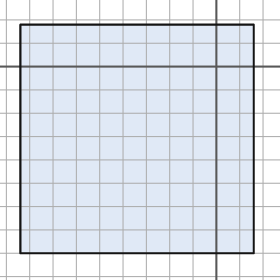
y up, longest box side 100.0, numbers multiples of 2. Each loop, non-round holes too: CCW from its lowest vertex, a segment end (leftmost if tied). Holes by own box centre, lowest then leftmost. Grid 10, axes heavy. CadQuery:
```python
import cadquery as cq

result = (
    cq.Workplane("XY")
    .moveTo(-84.0, -80.0)
    .lineTo(16.0, -80.0)
    .lineTo(16.0, 18.0)
    .lineTo(-84.0, 18.0)
    .close()
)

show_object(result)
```